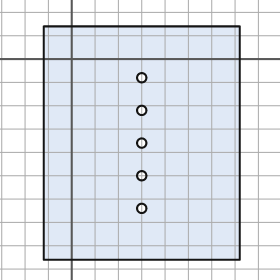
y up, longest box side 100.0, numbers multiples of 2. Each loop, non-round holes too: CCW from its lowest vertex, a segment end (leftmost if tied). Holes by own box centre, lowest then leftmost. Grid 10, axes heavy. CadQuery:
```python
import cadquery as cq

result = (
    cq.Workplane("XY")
    .moveTo(-12.0, -86.0)
    .lineTo(72.0, -86.0)
    .lineTo(72.0, 14.0)
    .lineTo(-12.0, 14.0)
    .close()
    .moveTo(30.0, -64.0)
    .circle(2.0)
    .moveTo(30.0, -50.0)
    .circle(2.0)
    .moveTo(30.0, -36.0)
    .circle(2.0)
    .moveTo(30.0, -22.0)
    .circle(2.0)
    .moveTo(30.0, -8.0)
    .circle(2.0)
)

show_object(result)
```